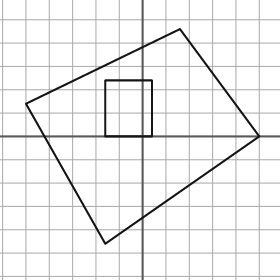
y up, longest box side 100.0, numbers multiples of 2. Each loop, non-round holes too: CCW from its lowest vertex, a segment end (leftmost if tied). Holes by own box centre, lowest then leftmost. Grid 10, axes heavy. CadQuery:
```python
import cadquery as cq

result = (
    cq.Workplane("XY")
    .moveTo(-16.0, -46.0)
    .lineTo(50.0, 0.0)
    .lineTo(16.0, 46.0)
    .lineTo(-50.0, 14.0)
    .close()
    .moveTo(-16.0, 0.0)
    .lineTo(4.0, 0.0)
    .lineTo(4.0, 24.0)
    .lineTo(-16.0, 24.0)
    .close()
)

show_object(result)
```